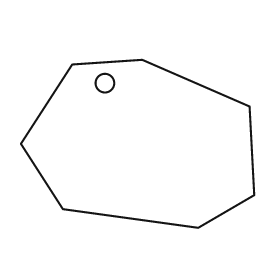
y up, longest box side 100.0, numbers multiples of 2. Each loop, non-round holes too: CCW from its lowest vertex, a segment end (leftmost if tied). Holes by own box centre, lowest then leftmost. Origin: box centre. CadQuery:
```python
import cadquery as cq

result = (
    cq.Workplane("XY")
    .moveTo(26.0, -36.0)
    .lineTo(50.0, -22.0)
    .lineTo(48.0, 16.0)
    .lineTo(2.0, 36.0)
    .lineTo(-28.0, 34.0)
    .lineTo(-50.0, 0.0)
    .lineTo(-32.0, -28.0)
    .close()
    .moveTo(-14.0, 26.0)
    .circle(4.0)
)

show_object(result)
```